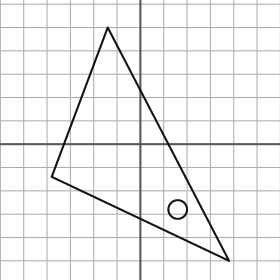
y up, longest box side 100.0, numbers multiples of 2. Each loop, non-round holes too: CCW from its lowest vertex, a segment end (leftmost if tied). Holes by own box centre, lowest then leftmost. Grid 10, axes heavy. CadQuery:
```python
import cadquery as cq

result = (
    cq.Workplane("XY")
    .moveTo(38.0, -50.0)
    .lineTo(-14.0, 50.0)
    .lineTo(-38.0, -14.0)
    .close()
    .moveTo(16.0, -28.0)
    .circle(4.0)
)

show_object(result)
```